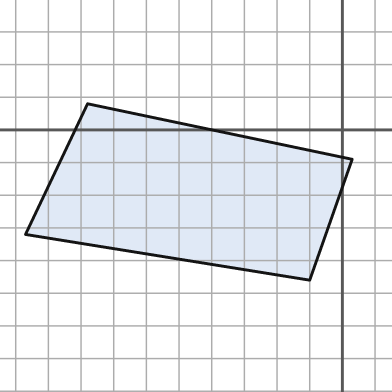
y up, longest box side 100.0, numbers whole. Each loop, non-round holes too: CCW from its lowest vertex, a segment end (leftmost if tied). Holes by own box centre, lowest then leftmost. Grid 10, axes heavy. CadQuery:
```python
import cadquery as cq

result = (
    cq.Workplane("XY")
    .moveTo(-10.0, -46.0)
    .lineTo(3.0, -9.0)
    .lineTo(-78.0, 8.0)
    .lineTo(-97.0, -32.0)
    .close()
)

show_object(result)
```